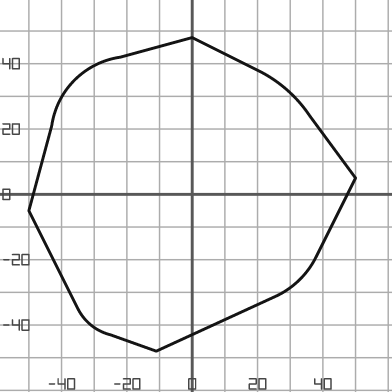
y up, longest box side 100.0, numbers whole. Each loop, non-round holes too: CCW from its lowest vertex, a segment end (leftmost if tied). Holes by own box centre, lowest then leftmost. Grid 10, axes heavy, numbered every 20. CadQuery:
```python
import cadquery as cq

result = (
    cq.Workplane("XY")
    .moveTo(-11.0, -48.0)
    .lineTo(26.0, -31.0)
    .threePointArc((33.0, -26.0), (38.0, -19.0))
    .lineTo(50.0, 5.0)
    .lineTo(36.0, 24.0)
    .threePointArc((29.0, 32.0), (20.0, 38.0))
    .lineTo(0.0, 48.0)
    .lineTo(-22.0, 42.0)
    .threePointArc((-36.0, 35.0), (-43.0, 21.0))
    .lineTo(-50.0, -5.0)
    .lineTo(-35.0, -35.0)
    .threePointArc((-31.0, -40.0), (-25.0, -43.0))
    .close()
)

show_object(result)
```